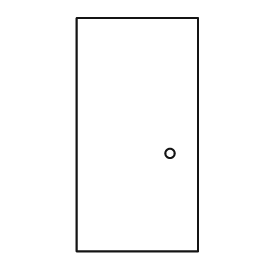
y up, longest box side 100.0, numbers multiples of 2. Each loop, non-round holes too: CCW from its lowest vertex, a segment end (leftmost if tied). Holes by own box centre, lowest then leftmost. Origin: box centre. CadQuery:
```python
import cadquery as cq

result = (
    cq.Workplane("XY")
    .moveTo(-26.0, -50.0)
    .lineTo(26.0, -50.0)
    .lineTo(26.0, 50.0)
    .lineTo(-26.0, 50.0)
    .close()
    .moveTo(14.0, -8.0)
    .circle(2.0)
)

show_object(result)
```